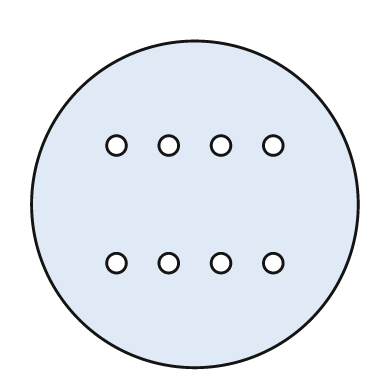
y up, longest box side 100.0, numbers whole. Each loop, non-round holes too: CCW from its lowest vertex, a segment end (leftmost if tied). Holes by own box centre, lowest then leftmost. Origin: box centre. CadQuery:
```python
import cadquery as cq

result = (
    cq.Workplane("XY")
    .moveTo(0.0, 0.0)
    .circle(50.0)
    .moveTo(-24.0, -18.0)
    .circle(3.0)
    .moveTo(-8.0, -18.0)
    .circle(3.0)
    .moveTo(8.0, -18.0)
    .circle(3.0)
    .moveTo(24.0, -18.0)
    .circle(3.0)
    .moveTo(-24.0, 18.0)
    .circle(3.0)
    .moveTo(-8.0, 18.0)
    .circle(3.0)
    .moveTo(8.0, 18.0)
    .circle(3.0)
    .moveTo(24.0, 18.0)
    .circle(3.0)
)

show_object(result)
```